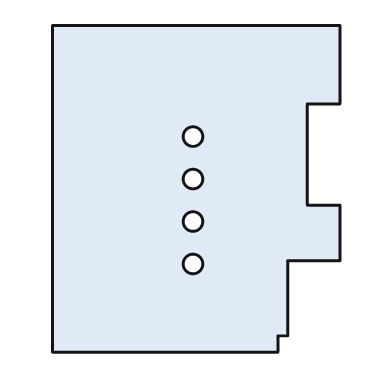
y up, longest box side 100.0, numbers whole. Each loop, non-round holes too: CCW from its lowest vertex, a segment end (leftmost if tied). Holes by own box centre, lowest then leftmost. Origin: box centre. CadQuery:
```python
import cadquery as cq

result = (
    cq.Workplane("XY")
    .moveTo(-44.0, -50.0)
    .lineTo(25.0, -50.0)
    .lineTo(25.0, -45.0)
    .lineTo(28.0, -45.0)
    .lineTo(28.0, -22.0)
    .lineTo(44.0, -22.0)
    .lineTo(44.0, -5.0)
    .lineTo(34.0, -5.0)
    .lineTo(34.0, 26.0)
    .lineTo(44.0, 26.0)
    .lineTo(44.0, 50.0)
    .lineTo(-44.0, 50.0)
    .close()
    .moveTo(-1.0, -23.0)
    .circle(3.0)
    .moveTo(-1.0, -10.0)
    .circle(3.0)
    .moveTo(-1.0, 3.0)
    .circle(3.0)
    .moveTo(-1.0, 16.0)
    .circle(3.0)
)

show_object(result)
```